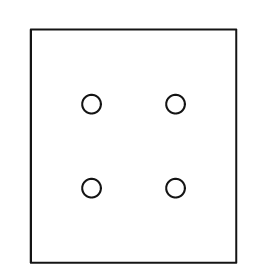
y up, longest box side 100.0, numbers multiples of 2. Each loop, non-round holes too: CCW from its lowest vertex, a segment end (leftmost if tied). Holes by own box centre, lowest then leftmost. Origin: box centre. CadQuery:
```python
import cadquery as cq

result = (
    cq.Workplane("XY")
    .moveTo(-44.0, -50.0)
    .lineTo(44.0, -50.0)
    .lineTo(44.0, 50.0)
    .lineTo(-44.0, 50.0)
    .close()
    .moveTo(-18.0, -18.0)
    .circle(4.0)
    .moveTo(18.0, -18.0)
    .circle(4.0)
    .moveTo(-18.0, 18.0)
    .circle(4.0)
    .moveTo(18.0, 18.0)
    .circle(4.0)
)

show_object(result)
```